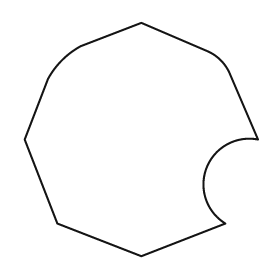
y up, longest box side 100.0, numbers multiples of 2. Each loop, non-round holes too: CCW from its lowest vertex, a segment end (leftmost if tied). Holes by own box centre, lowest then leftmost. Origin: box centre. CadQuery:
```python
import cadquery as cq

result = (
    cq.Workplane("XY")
    .moveTo(0.0, -50.0)
    .lineTo(36.0, -36.0)
    .threePointArc((28.0, -12.0), (50.0, 0.0))
    .lineTo(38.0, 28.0)
    .threePointArc((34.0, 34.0), (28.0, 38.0))
    .lineTo(0.0, 50.0)
    .lineTo(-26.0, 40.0)
    .threePointArc((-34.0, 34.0), (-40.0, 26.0))
    .lineTo(-50.0, 0.0)
    .lineTo(-36.0, -36.0)
    .close()
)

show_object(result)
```